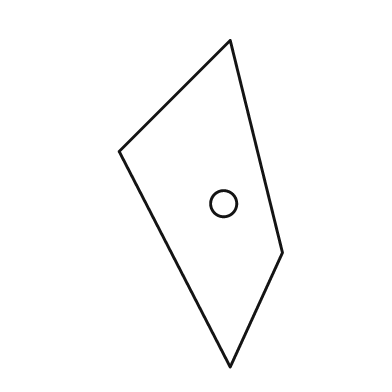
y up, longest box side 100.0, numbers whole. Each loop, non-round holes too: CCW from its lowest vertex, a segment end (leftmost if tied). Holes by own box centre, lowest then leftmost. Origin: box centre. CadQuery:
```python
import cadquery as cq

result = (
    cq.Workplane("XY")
    .moveTo(9.0, -50.0)
    .lineTo(25.0, -15.0)
    .lineTo(9.0, 50.0)
    .lineTo(-25.0, 16.0)
    .close()
    .moveTo(7.0, 0.0)
    .circle(4.0)
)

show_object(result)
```